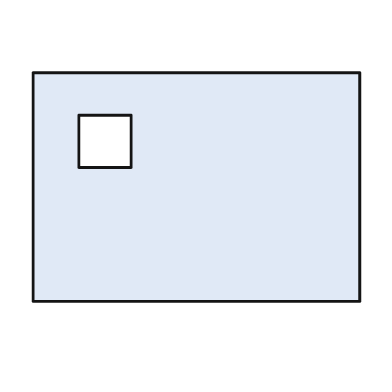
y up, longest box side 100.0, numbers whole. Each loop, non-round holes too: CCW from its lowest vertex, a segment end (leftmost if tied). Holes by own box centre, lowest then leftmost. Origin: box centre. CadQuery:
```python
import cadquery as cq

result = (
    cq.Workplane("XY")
    .moveTo(-50.0, -35.0)
    .lineTo(50.0, -35.0)
    .lineTo(50.0, 35.0)
    .lineTo(-50.0, 35.0)
    .close()
    .moveTo(-36.0, 6.0)
    .lineTo(-20.0, 6.0)
    .lineTo(-20.0, 22.0)
    .lineTo(-36.0, 22.0)
    .close()
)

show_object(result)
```